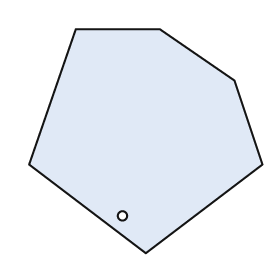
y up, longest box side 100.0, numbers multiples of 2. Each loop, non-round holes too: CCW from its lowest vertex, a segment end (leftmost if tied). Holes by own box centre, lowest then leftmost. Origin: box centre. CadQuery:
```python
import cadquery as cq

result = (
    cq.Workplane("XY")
    .moveTo(0.0, -48.0)
    .lineTo(50.0, -10.0)
    .lineTo(38.0, 26.0)
    .lineTo(6.0, 48.0)
    .lineTo(-30.0, 48.0)
    .lineTo(-50.0, -10.0)
    .close()
    .moveTo(-10.0, -32.0)
    .circle(2.0)
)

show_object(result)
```